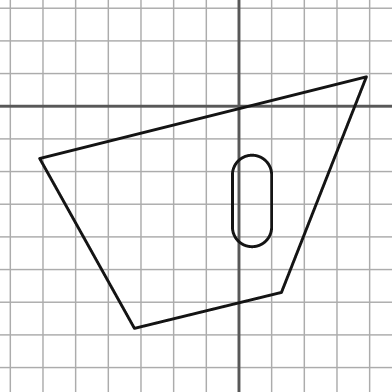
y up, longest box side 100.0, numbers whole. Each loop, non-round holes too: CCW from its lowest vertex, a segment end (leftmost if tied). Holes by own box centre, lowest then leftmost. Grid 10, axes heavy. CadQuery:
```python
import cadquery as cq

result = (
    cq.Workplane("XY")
    .moveTo(-32.0, -68.0)
    .lineTo(13.0, -57.0)
    .lineTo(39.0, 9.0)
    .lineTo(-61.0, -16.0)
    .close()
    .moveTo(-2.0, -37.0)
    .threePointArc((4.0, -43.0), (10.0, -37.0))
    .lineTo(10.0, -21.0)
    .threePointArc((4.0, -15.0), (-2.0, -21.0))
    .close()
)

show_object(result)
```